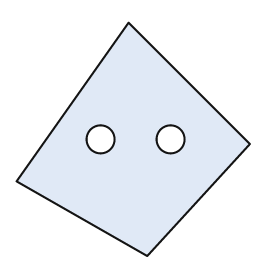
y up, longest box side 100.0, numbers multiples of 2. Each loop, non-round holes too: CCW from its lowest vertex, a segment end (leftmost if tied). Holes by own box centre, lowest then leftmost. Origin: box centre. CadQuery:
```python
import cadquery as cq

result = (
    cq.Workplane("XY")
    .moveTo(6.0, -50.0)
    .lineTo(50.0, -2.0)
    .lineTo(-2.0, 50.0)
    .lineTo(-50.0, -18.0)
    .close()
    .moveTo(-14.0, 0.0)
    .circle(6.0)
    .moveTo(16.0, 0.0)
    .circle(6.0)
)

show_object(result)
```